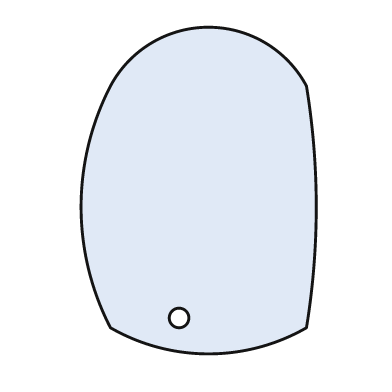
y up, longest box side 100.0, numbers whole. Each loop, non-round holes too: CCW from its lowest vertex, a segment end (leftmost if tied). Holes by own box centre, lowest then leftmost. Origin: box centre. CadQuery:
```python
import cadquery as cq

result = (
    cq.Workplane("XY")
    .moveTo(-27.0, -42.0)
    .threePointArc((3.0, -50.0), (33.0, -42.0))
    .threePointArc((36.0, -5.0), (33.0, 32.0))
    .threePointArc((3.0, 50.0), (-27.0, 32.0))
    .threePointArc((-36.0, -5.0), (-27.0, -42.0))
    .close()
    .moveTo(-6.0, -39.0)
    .circle(3.0)
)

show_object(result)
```